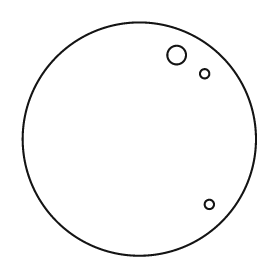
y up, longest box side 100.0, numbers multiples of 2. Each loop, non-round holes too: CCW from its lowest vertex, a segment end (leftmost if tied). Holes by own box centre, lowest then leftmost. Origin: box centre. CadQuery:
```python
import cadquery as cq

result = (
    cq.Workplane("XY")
    .moveTo(0.0, 0.0)
    .circle(50.0)
    .moveTo(30.0, -28.0)
    .circle(2.0)
    .moveTo(28.0, 28.0)
    .circle(2.0)
    .moveTo(16.0, 36.0)
    .circle(4.0)
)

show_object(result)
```